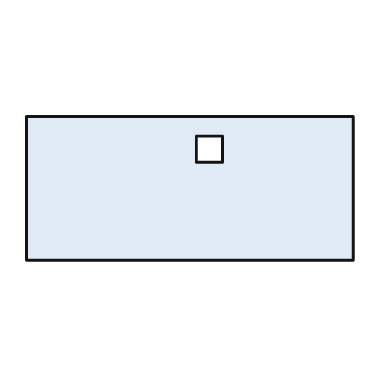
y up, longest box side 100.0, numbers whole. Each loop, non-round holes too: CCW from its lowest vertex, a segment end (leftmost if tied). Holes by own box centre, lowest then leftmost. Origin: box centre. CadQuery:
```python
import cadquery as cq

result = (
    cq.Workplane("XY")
    .moveTo(-50.0, -22.0)
    .lineTo(50.0, -22.0)
    .lineTo(50.0, 22.0)
    .lineTo(-50.0, 22.0)
    .close()
    .moveTo(2.0, 8.0)
    .lineTo(10.0, 8.0)
    .lineTo(10.0, 16.0)
    .lineTo(2.0, 16.0)
    .close()
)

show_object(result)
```